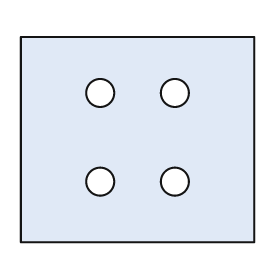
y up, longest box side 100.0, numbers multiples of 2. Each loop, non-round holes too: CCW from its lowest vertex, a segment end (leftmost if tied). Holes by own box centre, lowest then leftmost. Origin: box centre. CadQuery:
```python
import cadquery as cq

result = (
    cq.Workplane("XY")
    .moveTo(-50.0, -44.0)
    .lineTo(50.0, -44.0)
    .lineTo(50.0, 44.0)
    .lineTo(-50.0, 44.0)
    .close()
    .moveTo(-16.0, -18.0)
    .circle(6.0)
    .moveTo(16.0, -18.0)
    .circle(6.0)
    .moveTo(-16.0, 20.0)
    .circle(6.0)
    .moveTo(16.0, 20.0)
    .circle(6.0)
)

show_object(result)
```